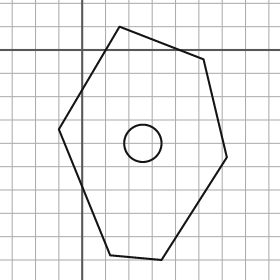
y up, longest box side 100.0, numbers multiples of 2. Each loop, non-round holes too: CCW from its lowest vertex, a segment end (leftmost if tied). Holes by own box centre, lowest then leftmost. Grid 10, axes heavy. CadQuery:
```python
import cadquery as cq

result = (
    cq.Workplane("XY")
    .moveTo(34.0, -90.0)
    .lineTo(62.0, -46.0)
    .lineTo(52.0, -4.0)
    .lineTo(16.0, 10.0)
    .lineTo(-10.0, -34.0)
    .lineTo(12.0, -88.0)
    .close()
    .moveTo(26.0, -40.0)
    .circle(8.0)
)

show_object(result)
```